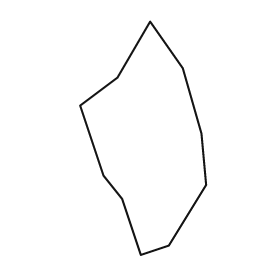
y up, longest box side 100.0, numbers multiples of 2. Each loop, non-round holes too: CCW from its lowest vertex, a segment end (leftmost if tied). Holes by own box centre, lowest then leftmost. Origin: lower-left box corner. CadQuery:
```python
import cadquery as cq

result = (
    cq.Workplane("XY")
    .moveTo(26.0, 0.0)
    .lineTo(38.0, 4.0)
    .lineTo(54.0, 30.0)
    .lineTo(52.0, 52.0)
    .lineTo(44.0, 80.0)
    .lineTo(30.0, 100.0)
    .lineTo(16.0, 76.0)
    .lineTo(0.0, 64.0)
    .lineTo(10.0, 34.0)
    .lineTo(18.0, 24.0)
    .close()
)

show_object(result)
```